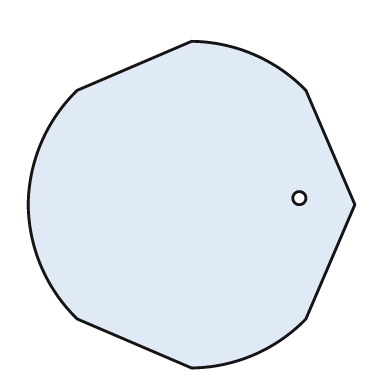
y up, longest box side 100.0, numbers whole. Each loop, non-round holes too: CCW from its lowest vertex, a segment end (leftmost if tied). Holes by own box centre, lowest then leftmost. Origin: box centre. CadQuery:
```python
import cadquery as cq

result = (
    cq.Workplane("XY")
    .moveTo(0.0, -50.0)
    .threePointArc((19.0, -46.0), (35.0, -35.0))
    .lineTo(50.0, 0.0)
    .lineTo(35.0, 35.0)
    .threePointArc((19.0, 46.0), (0.0, 50.0))
    .lineTo(-35.0, 35.0)
    .threePointArc((-46.0, 19.0), (-50.0, 0.0))
    .threePointArc((-46.0, -19.0), (-35.0, -35.0))
    .close()
    .moveTo(33.0, 2.0)
    .circle(2.0)
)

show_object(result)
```